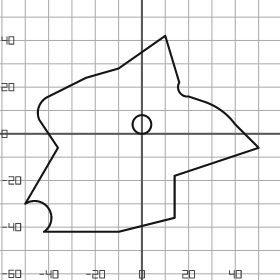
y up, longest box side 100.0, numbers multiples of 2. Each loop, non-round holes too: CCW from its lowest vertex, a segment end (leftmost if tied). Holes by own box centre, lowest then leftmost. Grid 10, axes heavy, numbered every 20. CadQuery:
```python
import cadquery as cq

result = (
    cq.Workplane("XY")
    .moveTo(-42.0, -42.0)
    .lineTo(-10.0, -42.0)
    .lineTo(14.0, -36.0)
    .lineTo(14.0, -18.0)
    .lineTo(50.0, -6.0)
    .lineTo(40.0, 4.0)
    .threePointArc((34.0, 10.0), (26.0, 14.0))
    .lineTo(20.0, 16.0)
    .threePointArc((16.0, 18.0), (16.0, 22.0))
    .lineTo(10.0, 42.0)
    .lineTo(-10.0, 28.0)
    .lineTo(-24.0, 24.0)
    .lineTo(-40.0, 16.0)
    .threePointArc((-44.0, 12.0), (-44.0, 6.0))
    .lineTo(-36.0, -6.0)
    .lineTo(-50.0, -30.0)
    .threePointArc((-40.0, -32.0), (-42.0, -42.0))
    .close()
    .moveTo(0.0, 4.0)
    .circle(4.0)
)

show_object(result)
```